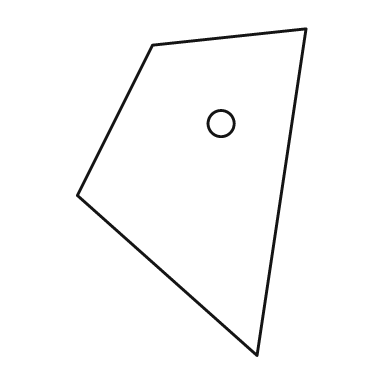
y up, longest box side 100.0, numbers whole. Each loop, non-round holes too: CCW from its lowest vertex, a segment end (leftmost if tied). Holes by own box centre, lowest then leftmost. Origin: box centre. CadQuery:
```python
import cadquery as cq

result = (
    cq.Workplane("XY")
    .moveTo(20.0, -50.0)
    .lineTo(35.0, 50.0)
    .lineTo(-12.0, 45.0)
    .lineTo(-35.0, -1.0)
    .close()
    .moveTo(9.0, 21.0)
    .circle(4.0)
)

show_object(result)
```